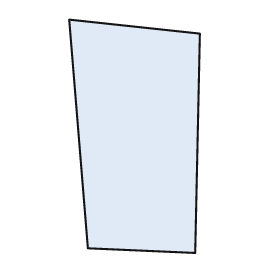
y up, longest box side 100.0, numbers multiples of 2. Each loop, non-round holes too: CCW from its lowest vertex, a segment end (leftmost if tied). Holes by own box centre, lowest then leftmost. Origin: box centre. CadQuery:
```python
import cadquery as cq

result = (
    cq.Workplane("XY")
    .moveTo(26.0, -50.0)
    .lineTo(28.0, 44.0)
    .lineTo(-28.0, 50.0)
    .lineTo(-20.0, -48.0)
    .close()
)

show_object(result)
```